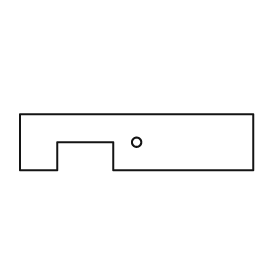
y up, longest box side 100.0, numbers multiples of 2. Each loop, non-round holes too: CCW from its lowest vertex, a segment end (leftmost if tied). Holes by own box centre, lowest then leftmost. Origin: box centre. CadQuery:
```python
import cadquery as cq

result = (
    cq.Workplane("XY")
    .moveTo(-50.0, -12.0)
    .lineTo(-34.0, -12.0)
    .lineTo(-34.0, 0.0)
    .lineTo(-10.0, 0.0)
    .lineTo(-10.0, -12.0)
    .lineTo(50.0, -12.0)
    .lineTo(50.0, 12.0)
    .lineTo(-50.0, 12.0)
    .close()
    .moveTo(0.0, 0.0)
    .circle(2.0)
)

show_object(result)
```